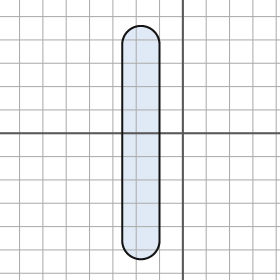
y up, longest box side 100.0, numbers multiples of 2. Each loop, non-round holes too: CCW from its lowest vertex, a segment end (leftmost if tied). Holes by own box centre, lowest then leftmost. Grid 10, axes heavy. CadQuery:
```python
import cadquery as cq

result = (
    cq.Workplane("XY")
    .moveTo(-26.0, -46.0)
    .threePointArc((-18.0, -54.0), (-10.0, -46.0))
    .lineTo(-10.0, 38.0)
    .threePointArc((-18.0, 46.0), (-26.0, 38.0))
    .close()
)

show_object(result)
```